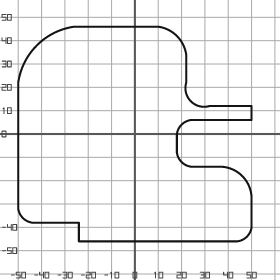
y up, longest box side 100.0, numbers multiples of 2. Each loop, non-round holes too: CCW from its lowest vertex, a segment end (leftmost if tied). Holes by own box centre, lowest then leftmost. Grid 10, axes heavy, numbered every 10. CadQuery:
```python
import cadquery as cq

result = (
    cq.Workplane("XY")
    .moveTo(-24.0, -46.0)
    .lineTo(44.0, -46.0)
    .threePointArc((48.0, -44.0), (50.0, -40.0))
    .lineTo(50.0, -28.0)
    .threePointArc((46.0, -18.0), (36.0, -14.0))
    .lineTo(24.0, -14.0)
    .threePointArc((20.0, -12.0), (18.0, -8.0))
    .lineTo(18.0, 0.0)
    .threePointArc((20.0, 4.0), (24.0, 6.0))
    .lineTo(50.0, 6.0)
    .lineTo(50.0, 12.0)
    .lineTo(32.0, 12.0)
    .threePointArc((24.0, 14.0), (22.0, 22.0))
    .lineTo(22.0, 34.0)
    .threePointArc((18.0, 42.0), (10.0, 46.0))
    .lineTo(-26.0, 46.0)
    .threePointArc((-42.0, 38.0), (-50.0, 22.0))
    .lineTo(-50.0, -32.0)
    .threePointArc((-48.0, -36.0), (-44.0, -38.0))
    .lineTo(-24.0, -38.0)
    .close()
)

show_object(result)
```